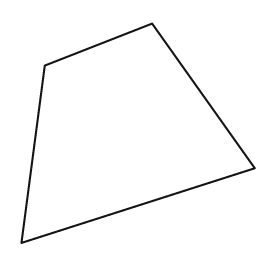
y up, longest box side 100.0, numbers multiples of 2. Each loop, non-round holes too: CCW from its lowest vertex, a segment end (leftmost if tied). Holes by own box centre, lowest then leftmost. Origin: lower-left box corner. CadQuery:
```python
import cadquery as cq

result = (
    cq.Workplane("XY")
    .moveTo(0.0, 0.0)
    .lineTo(100.0, 32.0)
    .lineTo(56.0, 94.0)
    .lineTo(10.0, 76.0)
    .close()
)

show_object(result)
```